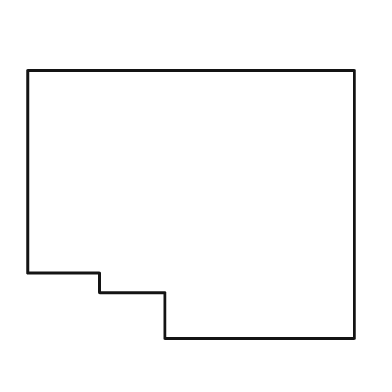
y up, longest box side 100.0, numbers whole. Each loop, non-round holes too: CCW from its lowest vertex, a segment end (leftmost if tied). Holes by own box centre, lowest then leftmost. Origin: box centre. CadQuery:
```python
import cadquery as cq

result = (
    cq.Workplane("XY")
    .moveTo(-8.0, -41.0)
    .lineTo(50.0, -41.0)
    .lineTo(50.0, 41.0)
    .lineTo(-50.0, 41.0)
    .lineTo(-50.0, -21.0)
    .lineTo(-28.0, -21.0)
    .lineTo(-28.0, -27.0)
    .lineTo(-8.0, -27.0)
    .close()
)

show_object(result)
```